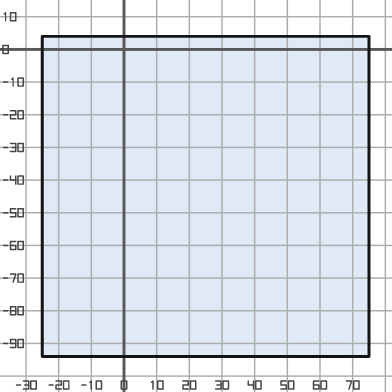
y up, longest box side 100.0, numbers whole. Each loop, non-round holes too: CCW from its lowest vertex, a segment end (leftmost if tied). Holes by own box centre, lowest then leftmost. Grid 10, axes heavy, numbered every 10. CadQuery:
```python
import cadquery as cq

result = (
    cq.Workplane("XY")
    .moveTo(-25.0, -94.0)
    .lineTo(75.0, -94.0)
    .lineTo(75.0, 4.0)
    .lineTo(-25.0, 4.0)
    .close()
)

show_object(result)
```